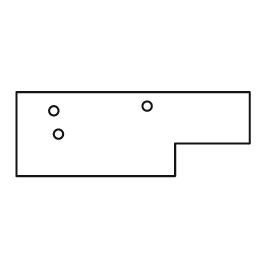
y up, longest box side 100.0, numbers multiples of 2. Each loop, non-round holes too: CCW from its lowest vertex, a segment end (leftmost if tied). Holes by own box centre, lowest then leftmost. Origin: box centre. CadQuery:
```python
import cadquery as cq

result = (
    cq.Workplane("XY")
    .moveTo(-50.0, -18.0)
    .lineTo(18.0, -18.0)
    .lineTo(18.0, -4.0)
    .lineTo(50.0, -4.0)
    .lineTo(50.0, 18.0)
    .lineTo(-50.0, 18.0)
    .close()
    .moveTo(-32.0, 0.0)
    .circle(2.0)
    .moveTo(-34.0, 10.0)
    .circle(2.0)
    .moveTo(6.0, 12.0)
    .circle(2.0)
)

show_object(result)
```